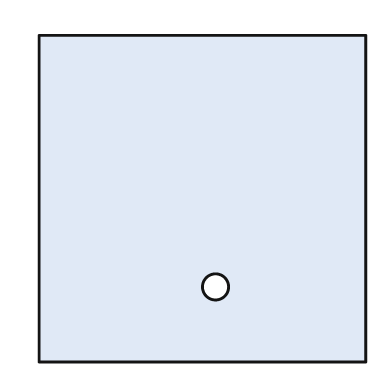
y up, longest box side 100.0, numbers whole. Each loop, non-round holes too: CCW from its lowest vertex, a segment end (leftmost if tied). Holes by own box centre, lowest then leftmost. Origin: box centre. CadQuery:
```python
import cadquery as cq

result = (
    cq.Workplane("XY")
    .moveTo(-50.0, -50.0)
    .lineTo(50.0, -50.0)
    .lineTo(50.0, 50.0)
    .lineTo(-50.0, 50.0)
    .close()
    .moveTo(4.0, -27.0)
    .circle(4.0)
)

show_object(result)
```